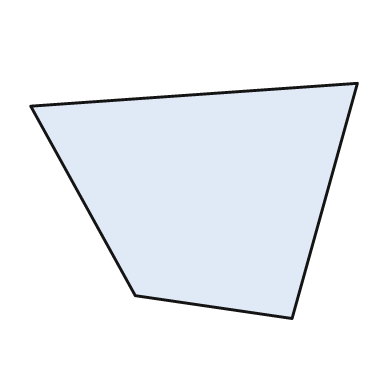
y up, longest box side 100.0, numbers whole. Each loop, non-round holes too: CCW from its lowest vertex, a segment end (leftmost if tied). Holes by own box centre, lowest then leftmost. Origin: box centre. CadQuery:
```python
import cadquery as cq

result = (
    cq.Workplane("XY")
    .moveTo(30.0, -36.0)
    .lineTo(50.0, 36.0)
    .lineTo(-50.0, 29.0)
    .lineTo(-18.0, -29.0)
    .close()
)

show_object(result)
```